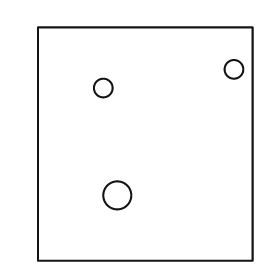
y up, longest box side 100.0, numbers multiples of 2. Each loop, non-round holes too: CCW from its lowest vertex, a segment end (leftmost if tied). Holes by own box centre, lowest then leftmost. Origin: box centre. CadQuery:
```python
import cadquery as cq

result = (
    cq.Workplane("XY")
    .moveTo(-46.0, -50.0)
    .lineTo(46.0, -50.0)
    .lineTo(46.0, 50.0)
    .lineTo(-46.0, 50.0)
    .close()
    .moveTo(-12.0, -22.0)
    .circle(6.0)
    .moveTo(-18.0, 24.0)
    .circle(4.0)
    .moveTo(38.0, 32.0)
    .circle(4.0)
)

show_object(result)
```